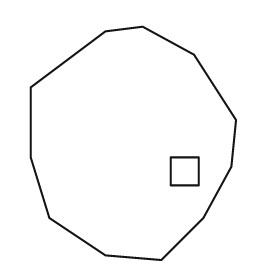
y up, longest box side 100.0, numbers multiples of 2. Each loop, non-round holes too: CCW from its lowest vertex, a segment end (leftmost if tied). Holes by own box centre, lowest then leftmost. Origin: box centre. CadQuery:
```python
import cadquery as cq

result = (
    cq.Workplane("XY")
    .moveTo(12.0, -50.0)
    .lineTo(30.0, -32.0)
    .lineTo(42.0, -10.0)
    .lineTo(44.0, 10.0)
    .lineTo(26.0, 38.0)
    .lineTo(4.0, 50.0)
    .lineTo(-12.0, 48.0)
    .lineTo(-44.0, 24.0)
    .lineTo(-44.0, -6.0)
    .lineTo(-36.0, -32.0)
    .lineTo(-12.0, -48.0)
    .close()
    .moveTo(16.0, -18.0)
    .lineTo(28.0, -18.0)
    .lineTo(28.0, -6.0)
    .lineTo(16.0, -6.0)
    .close()
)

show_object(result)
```